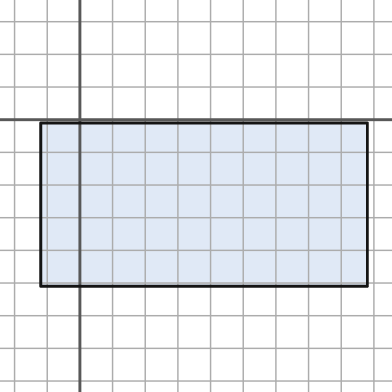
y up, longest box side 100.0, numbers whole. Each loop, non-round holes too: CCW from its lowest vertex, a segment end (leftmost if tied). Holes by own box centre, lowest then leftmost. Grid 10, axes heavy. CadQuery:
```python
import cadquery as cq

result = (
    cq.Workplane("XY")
    .moveTo(-12.0, -51.0)
    .lineTo(88.0, -51.0)
    .lineTo(88.0, -1.0)
    .lineTo(-12.0, -1.0)
    .close()
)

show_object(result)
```